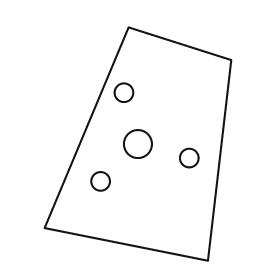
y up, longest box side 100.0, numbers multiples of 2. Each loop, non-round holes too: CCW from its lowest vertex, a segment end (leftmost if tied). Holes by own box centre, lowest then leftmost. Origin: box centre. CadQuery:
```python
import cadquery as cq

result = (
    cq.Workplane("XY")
    .moveTo(30.0, -50.0)
    .lineTo(40.0, 36.0)
    .lineTo(-4.0, 50.0)
    .lineTo(-40.0, -36.0)
    .close()
    .moveTo(-16.0, -16.0)
    .circle(4.0)
    .moveTo(22.0, -6.0)
    .circle(4.0)
    .moveTo(0.0, 0.0)
    .circle(6.0)
    .moveTo(-6.0, 22.0)
    .circle(4.0)
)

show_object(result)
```